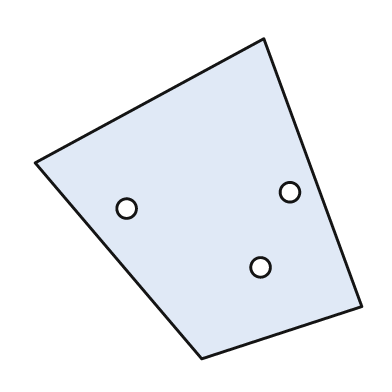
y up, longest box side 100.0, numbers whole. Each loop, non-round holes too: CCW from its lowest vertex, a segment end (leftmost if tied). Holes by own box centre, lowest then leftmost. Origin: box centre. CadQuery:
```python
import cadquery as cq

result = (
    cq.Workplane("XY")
    .moveTo(1.0, -49.0)
    .lineTo(50.0, -33.0)
    .lineTo(20.0, 49.0)
    .lineTo(-50.0, 11.0)
    .close()
    .moveTo(19.0, -21.0)
    .circle(3.0)
    .moveTo(-22.0, -3.0)
    .circle(3.0)
    .moveTo(28.0, 2.0)
    .circle(3.0)
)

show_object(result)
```